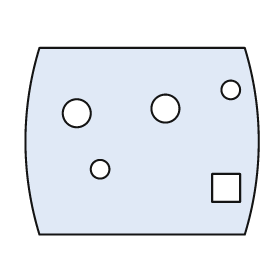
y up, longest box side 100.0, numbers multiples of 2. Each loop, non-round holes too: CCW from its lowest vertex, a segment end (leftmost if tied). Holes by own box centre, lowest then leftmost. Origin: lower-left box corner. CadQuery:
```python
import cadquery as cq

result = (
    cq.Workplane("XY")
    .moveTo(6.0, 0.0)
    .lineTo(94.0, 0.0)
    .threePointArc((100.0, 40.0), (94.0, 80.0))
    .lineTo(6.0, 80.0)
    .threePointArc((0.0, 40.0), (6.0, 0.0))
    .close()
    .moveTo(80.0, 14.0)
    .lineTo(92.0, 14.0)
    .lineTo(92.0, 26.0)
    .lineTo(80.0, 26.0)
    .close()
    .moveTo(32.0, 28.0)
    .circle(4.0)
    .moveTo(22.0, 52.0)
    .circle(6.0)
    .moveTo(60.0, 54.0)
    .circle(6.0)
    .moveTo(88.0, 62.0)
    .circle(4.0)
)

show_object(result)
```